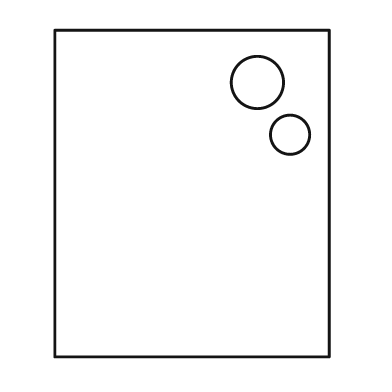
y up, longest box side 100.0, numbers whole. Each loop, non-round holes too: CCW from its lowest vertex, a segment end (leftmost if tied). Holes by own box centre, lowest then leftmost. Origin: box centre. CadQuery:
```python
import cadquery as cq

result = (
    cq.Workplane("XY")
    .moveTo(-42.0, -50.0)
    .lineTo(42.0, -50.0)
    .lineTo(42.0, 50.0)
    .lineTo(-42.0, 50.0)
    .close()
    .moveTo(30.0, 18.0)
    .circle(6.0)
    .moveTo(20.0, 34.0)
    .circle(8.0)
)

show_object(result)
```